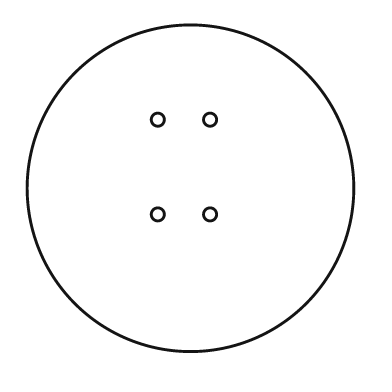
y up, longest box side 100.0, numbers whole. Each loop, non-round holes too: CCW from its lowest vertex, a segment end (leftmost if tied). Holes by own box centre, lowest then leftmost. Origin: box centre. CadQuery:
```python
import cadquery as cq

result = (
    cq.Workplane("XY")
    .moveTo(0.0, 0.0)
    .circle(50.0)
    .moveTo(-10.0, -8.0)
    .circle(2.0)
    .moveTo(6.0, -8.0)
    .circle(2.0)
    .moveTo(-10.0, 21.0)
    .circle(2.0)
    .moveTo(6.0, 21.0)
    .circle(2.0)
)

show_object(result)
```